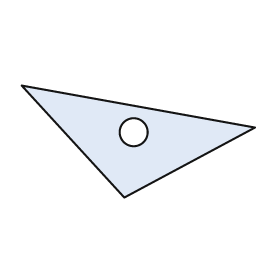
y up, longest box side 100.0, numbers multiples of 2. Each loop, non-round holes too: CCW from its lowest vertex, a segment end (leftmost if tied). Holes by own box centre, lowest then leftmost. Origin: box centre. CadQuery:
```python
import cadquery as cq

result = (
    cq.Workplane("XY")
    .moveTo(-6.0, -24.0)
    .lineTo(50.0, 6.0)
    .lineTo(-50.0, 24.0)
    .close()
    .moveTo(-2.0, 4.0)
    .circle(6.0)
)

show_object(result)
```